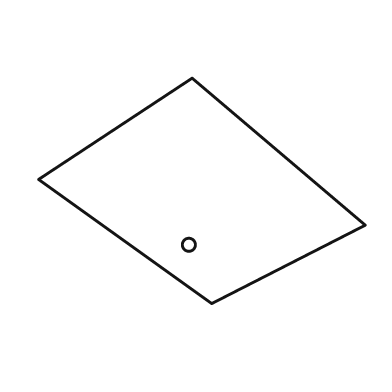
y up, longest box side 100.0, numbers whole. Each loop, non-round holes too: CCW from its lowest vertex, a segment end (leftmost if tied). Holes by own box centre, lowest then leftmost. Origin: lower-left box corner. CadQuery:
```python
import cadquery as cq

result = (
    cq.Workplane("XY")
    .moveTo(53.0, 0.0)
    .lineTo(100.0, 24.0)
    .lineTo(47.0, 69.0)
    .lineTo(0.0, 38.0)
    .close()
    .moveTo(46.0, 18.0)
    .circle(2.0)
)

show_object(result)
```